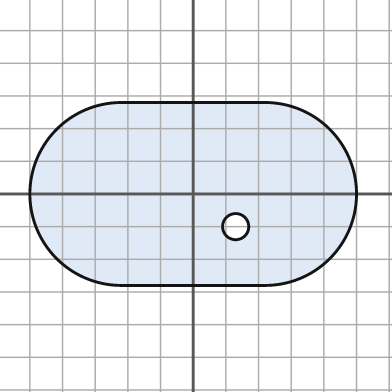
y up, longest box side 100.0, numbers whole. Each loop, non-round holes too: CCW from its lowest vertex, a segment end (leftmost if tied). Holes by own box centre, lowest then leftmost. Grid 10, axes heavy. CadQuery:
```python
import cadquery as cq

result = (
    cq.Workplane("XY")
    .moveTo(-22.0, -28.0)
    .lineTo(22.0, -28.0)
    .threePointArc((50.0, 0.0), (22.0, 28.0))
    .lineTo(-22.0, 28.0)
    .threePointArc((-50.0, 0.0), (-22.0, -28.0))
    .close()
    .moveTo(13.0, -10.0)
    .circle(4.0)
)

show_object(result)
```